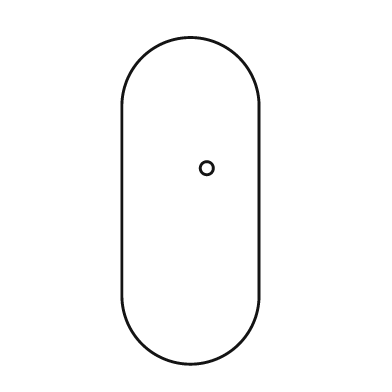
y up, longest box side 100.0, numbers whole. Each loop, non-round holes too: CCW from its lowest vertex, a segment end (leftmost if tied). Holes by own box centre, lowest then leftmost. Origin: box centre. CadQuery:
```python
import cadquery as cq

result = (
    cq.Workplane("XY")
    .moveTo(-21.0, -29.0)
    .threePointArc((0.0, -50.0), (21.0, -29.0))
    .lineTo(21.0, 29.0)
    .threePointArc((0.0, 50.0), (-21.0, 29.0))
    .close()
    .moveTo(5.0, 10.0)
    .circle(2.0)
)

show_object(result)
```